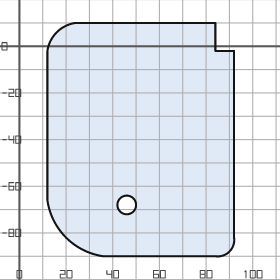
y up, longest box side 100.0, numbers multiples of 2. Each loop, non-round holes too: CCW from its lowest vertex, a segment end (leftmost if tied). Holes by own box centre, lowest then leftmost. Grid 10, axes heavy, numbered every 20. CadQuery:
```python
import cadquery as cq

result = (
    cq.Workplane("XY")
    .moveTo(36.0, -90.0)
    .lineTo(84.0, -90.0)
    .threePointArc((90.0, -88.0), (92.0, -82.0))
    .lineTo(92.0, -2.0)
    .lineTo(84.0, -2.0)
    .lineTo(84.0, 10.0)
    .lineTo(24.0, 10.0)
    .threePointArc((16.0, 6.0), (12.0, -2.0))
    .lineTo(12.0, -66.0)
    .threePointArc((20.0, -82.0), (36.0, -90.0))
    .close()
    .moveTo(46.0, -68.0)
    .circle(4.0)
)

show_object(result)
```